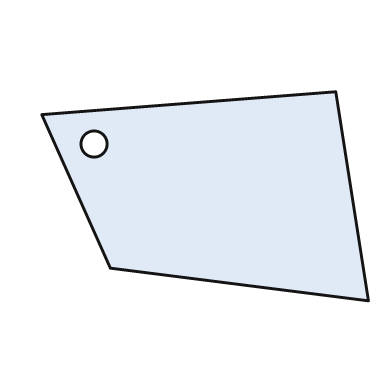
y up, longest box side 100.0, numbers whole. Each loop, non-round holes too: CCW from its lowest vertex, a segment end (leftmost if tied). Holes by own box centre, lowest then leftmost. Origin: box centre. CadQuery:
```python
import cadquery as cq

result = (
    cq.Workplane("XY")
    .moveTo(50.0, -32.0)
    .lineTo(40.0, 32.0)
    .lineTo(-50.0, 25.0)
    .lineTo(-29.0, -22.0)
    .close()
    .moveTo(-34.0, 16.0)
    .circle(4.0)
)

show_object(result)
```